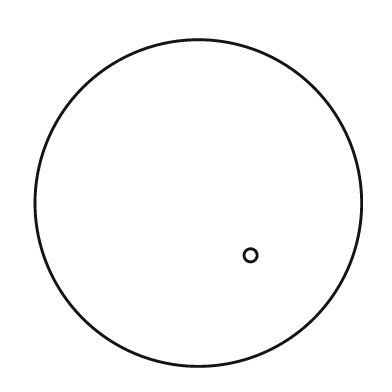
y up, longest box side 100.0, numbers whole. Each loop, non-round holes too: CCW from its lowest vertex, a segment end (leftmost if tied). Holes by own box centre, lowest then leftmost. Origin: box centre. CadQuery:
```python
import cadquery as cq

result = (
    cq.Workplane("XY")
    .moveTo(0.0, 0.0)
    .circle(50.0)
    .moveTo(16.0, -16.0)
    .circle(2.0)
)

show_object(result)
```